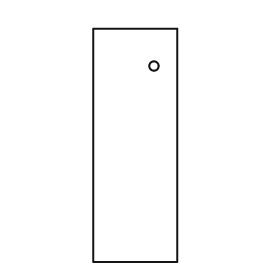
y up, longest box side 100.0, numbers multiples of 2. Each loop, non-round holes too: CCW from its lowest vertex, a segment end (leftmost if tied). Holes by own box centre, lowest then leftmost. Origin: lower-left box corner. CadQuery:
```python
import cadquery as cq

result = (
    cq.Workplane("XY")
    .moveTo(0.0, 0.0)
    .lineTo(36.0, 0.0)
    .lineTo(36.0, 100.0)
    .lineTo(0.0, 100.0)
    .close()
    .moveTo(26.0, 84.0)
    .circle(2.0)
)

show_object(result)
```